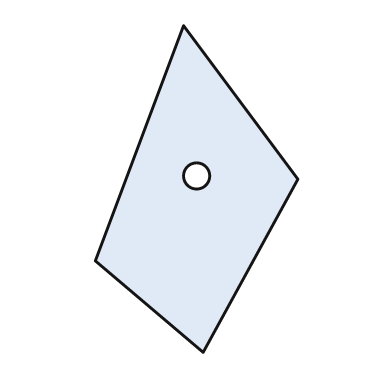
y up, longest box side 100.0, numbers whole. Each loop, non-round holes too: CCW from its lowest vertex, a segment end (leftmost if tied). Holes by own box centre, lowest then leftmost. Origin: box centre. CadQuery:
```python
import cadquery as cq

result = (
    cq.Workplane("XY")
    .moveTo(2.0, -50.0)
    .lineTo(31.0, 3.0)
    .lineTo(-4.0, 50.0)
    .lineTo(-31.0, -22.0)
    .close()
    .moveTo(0.0, 4.0)
    .circle(4.0)
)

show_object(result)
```